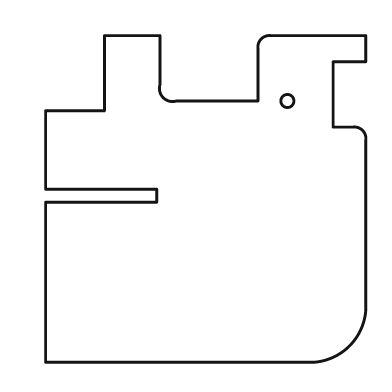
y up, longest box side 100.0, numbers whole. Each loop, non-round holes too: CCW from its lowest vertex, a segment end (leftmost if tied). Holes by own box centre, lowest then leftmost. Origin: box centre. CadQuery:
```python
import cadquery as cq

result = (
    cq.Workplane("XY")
    .moveTo(-49.0, -50.0)
    .lineTo(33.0, -50.0)
    .threePointArc((44.0, -45.0), (49.0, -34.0))
    .lineTo(49.0, 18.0)
    .threePointArc((48.0, 21.0), (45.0, 22.0))
    .lineTo(39.0, 22.0)
    .lineTo(39.0, 42.0)
    .lineTo(49.0, 42.0)
    .lineTo(49.0, 50.0)
    .lineTo(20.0, 50.0)
    .threePointArc((17.0, 49.0), (16.0, 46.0))
    .lineTo(16.0, 30.0)
    .lineTo(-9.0, 30.0)
    .threePointArc((-13.0, 31.0), (-14.0, 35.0))
    .lineTo(-14.0, 50.0)
    .lineTo(-31.0, 50.0)
    .lineTo(-31.0, 27.0)
    .lineTo(-49.0, 27.0)
    .lineTo(-49.0, 3.0)
    .lineTo(-15.0, 3.0)
    .lineTo(-15.0, -1.0)
    .lineTo(-49.0, -1.0)
    .close()
    .moveTo(25.0, 30.0)
    .circle(2.0)
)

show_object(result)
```